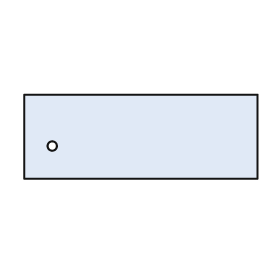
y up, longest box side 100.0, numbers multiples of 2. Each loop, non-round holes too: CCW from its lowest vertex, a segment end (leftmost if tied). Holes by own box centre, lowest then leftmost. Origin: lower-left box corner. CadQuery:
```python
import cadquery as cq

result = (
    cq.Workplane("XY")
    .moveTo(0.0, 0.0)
    .lineTo(100.0, 0.0)
    .lineTo(100.0, 36.0)
    .lineTo(0.0, 36.0)
    .close()
    .moveTo(12.0, 14.0)
    .circle(2.0)
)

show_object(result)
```